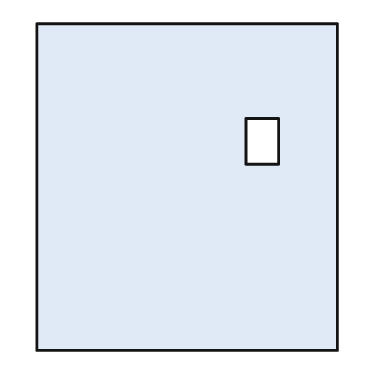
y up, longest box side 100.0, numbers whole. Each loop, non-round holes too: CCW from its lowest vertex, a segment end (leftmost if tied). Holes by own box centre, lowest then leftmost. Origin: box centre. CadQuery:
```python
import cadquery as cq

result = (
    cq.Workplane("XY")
    .moveTo(-46.0, -50.0)
    .lineTo(46.0, -50.0)
    .lineTo(46.0, 50.0)
    .lineTo(-46.0, 50.0)
    .close()
    .moveTo(18.0, 7.0)
    .lineTo(28.0, 7.0)
    .lineTo(28.0, 21.0)
    .lineTo(18.0, 21.0)
    .close()
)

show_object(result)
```